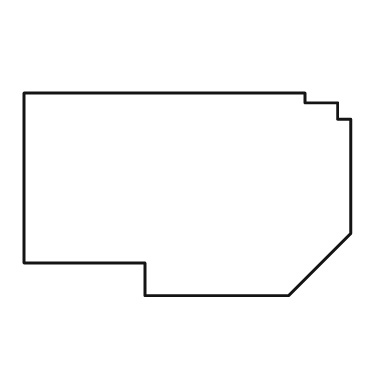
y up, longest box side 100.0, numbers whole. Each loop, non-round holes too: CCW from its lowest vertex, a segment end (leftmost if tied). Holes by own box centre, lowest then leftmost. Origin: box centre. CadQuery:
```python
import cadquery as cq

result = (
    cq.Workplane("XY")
    .moveTo(-13.0, -31.0)
    .lineTo(31.0, -31.0)
    .lineTo(50.0, -12.0)
    .lineTo(50.0, 23.0)
    .lineTo(46.0, 23.0)
    .lineTo(46.0, 28.0)
    .lineTo(36.0, 28.0)
    .lineTo(36.0, 31.0)
    .lineTo(-50.0, 31.0)
    .lineTo(-50.0, -21.0)
    .lineTo(-13.0, -21.0)
    .close()
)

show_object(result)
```